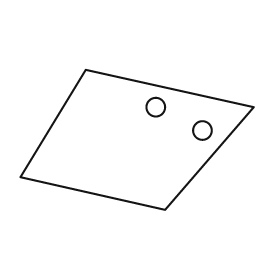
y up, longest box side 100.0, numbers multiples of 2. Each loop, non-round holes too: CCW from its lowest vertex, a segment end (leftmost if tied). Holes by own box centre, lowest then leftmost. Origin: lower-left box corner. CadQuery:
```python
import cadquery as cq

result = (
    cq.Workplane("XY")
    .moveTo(62.0, 0.0)
    .lineTo(100.0, 44.0)
    .lineTo(28.0, 60.0)
    .lineTo(0.0, 14.0)
    .close()
    .moveTo(78.0, 34.0)
    .circle(4.0)
    .moveTo(58.0, 44.0)
    .circle(4.0)
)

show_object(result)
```